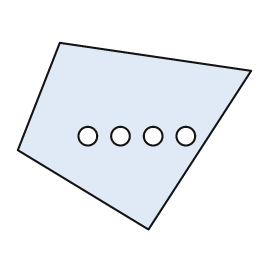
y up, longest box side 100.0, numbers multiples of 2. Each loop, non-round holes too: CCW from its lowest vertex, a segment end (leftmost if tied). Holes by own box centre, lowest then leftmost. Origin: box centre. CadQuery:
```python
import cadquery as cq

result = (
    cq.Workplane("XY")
    .moveTo(6.0, -40.0)
    .lineTo(50.0, 28.0)
    .lineTo(-32.0, 40.0)
    .lineTo(-50.0, -6.0)
    .close()
    .moveTo(-20.0, 0.0)
    .circle(4.0)
    .moveTo(-6.0, 0.0)
    .circle(4.0)
    .moveTo(8.0, 0.0)
    .circle(4.0)
    .moveTo(22.0, 0.0)
    .circle(4.0)
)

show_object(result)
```